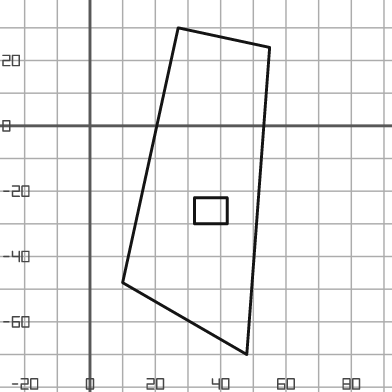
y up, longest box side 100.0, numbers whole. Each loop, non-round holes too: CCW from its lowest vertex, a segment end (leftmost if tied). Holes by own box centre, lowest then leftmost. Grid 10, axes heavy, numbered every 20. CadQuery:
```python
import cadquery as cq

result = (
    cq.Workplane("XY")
    .moveTo(48.0, -70.0)
    .lineTo(55.0, 24.0)
    .lineTo(27.0, 30.0)
    .lineTo(10.0, -48.0)
    .close()
    .moveTo(32.0, -30.0)
    .lineTo(42.0, -30.0)
    .lineTo(42.0, -22.0)
    .lineTo(32.0, -22.0)
    .close()
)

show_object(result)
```